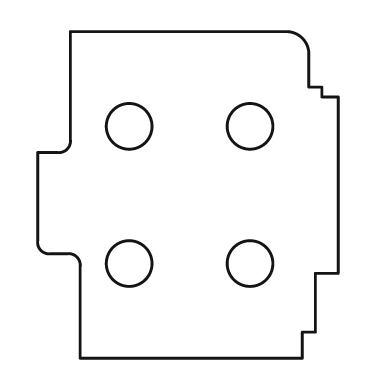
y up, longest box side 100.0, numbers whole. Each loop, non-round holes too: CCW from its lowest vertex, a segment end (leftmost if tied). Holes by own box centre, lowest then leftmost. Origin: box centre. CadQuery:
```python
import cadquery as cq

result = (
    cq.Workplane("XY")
    .moveTo(-33.0, -50.0)
    .lineTo(35.0, -50.0)
    .lineTo(35.0, -42.0)
    .lineTo(39.0, -42.0)
    .lineTo(39.0, -24.0)
    .lineTo(46.0, -24.0)
    .lineTo(46.0, 30.0)
    .lineTo(41.0, 30.0)
    .lineTo(41.0, 33.0)
    .lineTo(37.0, 33.0)
    .lineTo(37.0, 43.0)
    .threePointArc((35.0, 48.0), (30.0, 50.0))
    .lineTo(-36.0, 50.0)
    .lineTo(-36.0, 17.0)
    .threePointArc((-37.0, 14.0), (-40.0, 13.0))
    .lineTo(-46.0, 13.0)
    .lineTo(-46.0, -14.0)
    .threePointArc((-45.0, -17.0), (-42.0, -18.0))
    .lineTo(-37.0, -18.0)
    .threePointArc((-34.0, -19.0), (-33.0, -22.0))
    .close()
    .moveTo(-18.0, -21.0)
    .circle(7.0)
    .moveTo(19.0, -21.0)
    .circle(7.0)
    .moveTo(-18.0, 21.0)
    .circle(7.0)
    .moveTo(19.0, 21.0)
    .circle(7.0)
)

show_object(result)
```